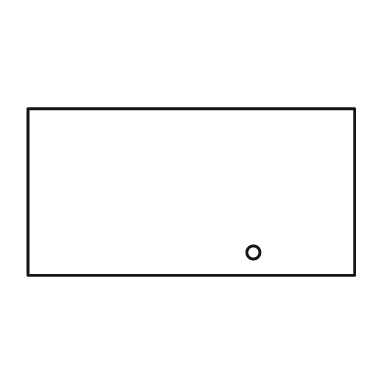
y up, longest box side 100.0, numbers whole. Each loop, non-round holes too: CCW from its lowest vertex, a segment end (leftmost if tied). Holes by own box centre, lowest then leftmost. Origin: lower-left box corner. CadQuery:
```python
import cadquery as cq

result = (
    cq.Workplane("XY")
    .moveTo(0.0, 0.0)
    .lineTo(100.0, 0.0)
    .lineTo(100.0, 51.0)
    .lineTo(0.0, 51.0)
    .close()
    .moveTo(69.0, 7.0)
    .circle(2.0)
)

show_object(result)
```